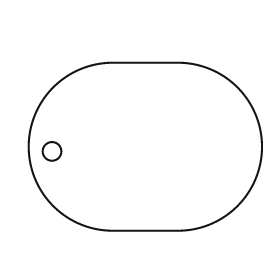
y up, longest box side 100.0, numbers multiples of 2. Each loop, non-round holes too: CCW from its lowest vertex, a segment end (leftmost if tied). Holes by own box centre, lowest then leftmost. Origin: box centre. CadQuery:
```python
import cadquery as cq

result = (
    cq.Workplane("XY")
    .moveTo(-14.0, -36.0)
    .lineTo(14.0, -36.0)
    .threePointArc((50.0, 0.0), (14.0, 36.0))
    .lineTo(-14.0, 36.0)
    .threePointArc((-50.0, 0.0), (-14.0, -36.0))
    .close()
    .moveTo(-40.0, -2.0)
    .circle(4.0)
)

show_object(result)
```